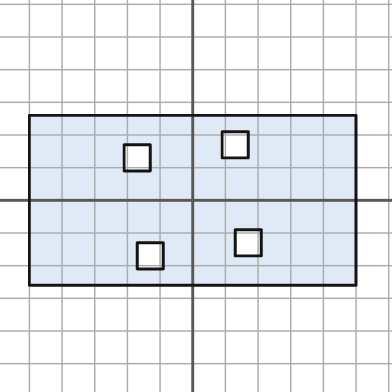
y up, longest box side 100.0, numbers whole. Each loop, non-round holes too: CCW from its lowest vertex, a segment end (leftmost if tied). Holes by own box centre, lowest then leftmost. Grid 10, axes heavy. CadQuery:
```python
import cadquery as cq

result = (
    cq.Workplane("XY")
    .moveTo(-50.0, -26.0)
    .lineTo(50.0, -26.0)
    .lineTo(50.0, 26.0)
    .lineTo(-50.0, 26.0)
    .close()
    .moveTo(-17.0, -21.0)
    .lineTo(-9.0, -21.0)
    .lineTo(-9.0, -13.0)
    .lineTo(-17.0, -13.0)
    .close()
    .moveTo(13.0, -17.0)
    .lineTo(21.0, -17.0)
    .lineTo(21.0, -9.0)
    .lineTo(13.0, -9.0)
    .close()
    .moveTo(-21.0, 9.0)
    .lineTo(-13.0, 9.0)
    .lineTo(-13.0, 17.0)
    .lineTo(-21.0, 17.0)
    .close()
    .moveTo(9.0, 13.0)
    .lineTo(17.0, 13.0)
    .lineTo(17.0, 21.0)
    .lineTo(9.0, 21.0)
    .close()
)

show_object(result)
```